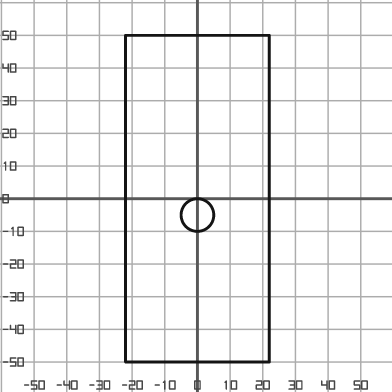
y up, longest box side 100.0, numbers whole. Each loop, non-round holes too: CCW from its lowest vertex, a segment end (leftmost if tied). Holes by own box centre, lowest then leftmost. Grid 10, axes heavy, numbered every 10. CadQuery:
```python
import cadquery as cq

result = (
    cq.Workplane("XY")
    .moveTo(-22.0, -50.0)
    .lineTo(22.0, -50.0)
    .lineTo(22.0, 50.0)
    .lineTo(-22.0, 50.0)
    .close()
    .moveTo(0.0, -5.0)
    .circle(5.0)
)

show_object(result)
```